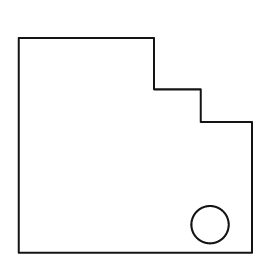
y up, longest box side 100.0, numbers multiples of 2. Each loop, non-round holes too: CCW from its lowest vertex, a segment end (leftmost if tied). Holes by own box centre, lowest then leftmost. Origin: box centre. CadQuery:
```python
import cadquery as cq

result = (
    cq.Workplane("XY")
    .moveTo(-50.0, -46.0)
    .lineTo(50.0, -46.0)
    .lineTo(50.0, 10.0)
    .lineTo(28.0, 10.0)
    .lineTo(28.0, 24.0)
    .lineTo(8.0, 24.0)
    .lineTo(8.0, 46.0)
    .lineTo(-50.0, 46.0)
    .close()
    .moveTo(32.0, -34.0)
    .circle(8.0)
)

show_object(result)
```